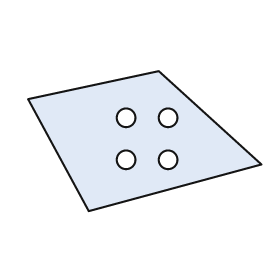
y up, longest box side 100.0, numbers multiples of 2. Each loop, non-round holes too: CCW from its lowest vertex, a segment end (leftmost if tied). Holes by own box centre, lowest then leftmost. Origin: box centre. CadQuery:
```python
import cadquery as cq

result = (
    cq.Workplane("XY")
    .moveTo(-24.0, -30.0)
    .lineTo(50.0, -10.0)
    .lineTo(6.0, 30.0)
    .lineTo(-50.0, 18.0)
    .close()
    .moveTo(-8.0, -8.0)
    .circle(4.0)
    .moveTo(10.0, -8.0)
    .circle(4.0)
    .moveTo(-8.0, 10.0)
    .circle(4.0)
    .moveTo(10.0, 10.0)
    .circle(4.0)
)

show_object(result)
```